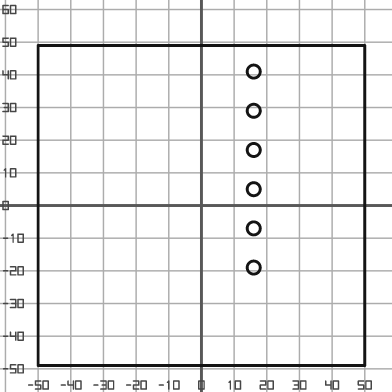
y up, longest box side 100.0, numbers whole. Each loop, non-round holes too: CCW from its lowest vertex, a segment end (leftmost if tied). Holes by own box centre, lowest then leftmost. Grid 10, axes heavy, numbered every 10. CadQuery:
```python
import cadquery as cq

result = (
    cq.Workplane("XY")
    .moveTo(-50.0, -49.0)
    .lineTo(50.0, -49.0)
    .lineTo(50.0, 49.0)
    .lineTo(-50.0, 49.0)
    .close()
    .moveTo(16.0, -19.0)
    .circle(2.0)
    .moveTo(16.0, -7.0)
    .circle(2.0)
    .moveTo(16.0, 5.0)
    .circle(2.0)
    .moveTo(16.0, 17.0)
    .circle(2.0)
    .moveTo(16.0, 29.0)
    .circle(2.0)
    .moveTo(16.0, 41.0)
    .circle(2.0)
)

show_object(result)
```